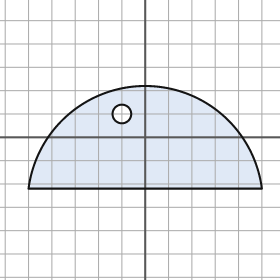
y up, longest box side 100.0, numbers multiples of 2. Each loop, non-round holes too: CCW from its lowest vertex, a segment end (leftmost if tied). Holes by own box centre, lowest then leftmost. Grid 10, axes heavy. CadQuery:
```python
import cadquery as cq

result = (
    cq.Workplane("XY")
    .moveTo(-50.0, -22.0)
    .lineTo(50.0, -22.0)
    .threePointArc((0.0, 22.0), (-50.0, -22.0))
    .close()
    .moveTo(-10.0, 10.0)
    .circle(4.0)
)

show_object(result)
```